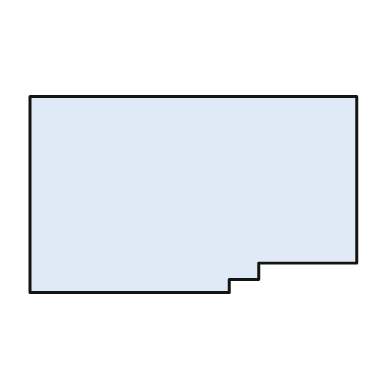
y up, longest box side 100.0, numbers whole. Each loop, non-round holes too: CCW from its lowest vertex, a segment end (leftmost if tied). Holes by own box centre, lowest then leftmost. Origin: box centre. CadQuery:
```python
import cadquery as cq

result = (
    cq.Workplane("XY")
    .moveTo(-50.0, -30.0)
    .lineTo(11.0, -30.0)
    .lineTo(11.0, -26.0)
    .lineTo(20.0, -26.0)
    .lineTo(20.0, -21.0)
    .lineTo(50.0, -21.0)
    .lineTo(50.0, 30.0)
    .lineTo(-50.0, 30.0)
    .close()
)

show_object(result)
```